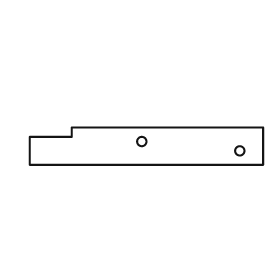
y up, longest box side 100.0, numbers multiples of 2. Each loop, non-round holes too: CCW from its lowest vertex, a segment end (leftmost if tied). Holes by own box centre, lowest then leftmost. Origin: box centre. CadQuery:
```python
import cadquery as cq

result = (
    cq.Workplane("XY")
    .moveTo(-50.0, -8.0)
    .lineTo(50.0, -8.0)
    .lineTo(50.0, 8.0)
    .lineTo(-32.0, 8.0)
    .lineTo(-32.0, 4.0)
    .lineTo(-50.0, 4.0)
    .close()
    .moveTo(40.0, -2.0)
    .circle(2.0)
    .moveTo(-2.0, 2.0)
    .circle(2.0)
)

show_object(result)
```